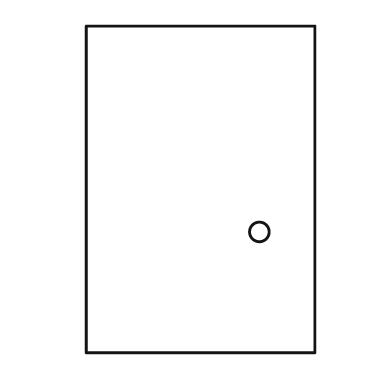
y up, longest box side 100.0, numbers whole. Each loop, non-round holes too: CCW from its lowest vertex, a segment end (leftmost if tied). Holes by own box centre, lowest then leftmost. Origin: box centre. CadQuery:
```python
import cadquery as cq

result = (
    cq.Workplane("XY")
    .moveTo(-35.0, -50.0)
    .lineTo(35.0, -50.0)
    .lineTo(35.0, 50.0)
    .lineTo(-35.0, 50.0)
    .close()
    .moveTo(18.0, -13.0)
    .circle(3.0)
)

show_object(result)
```